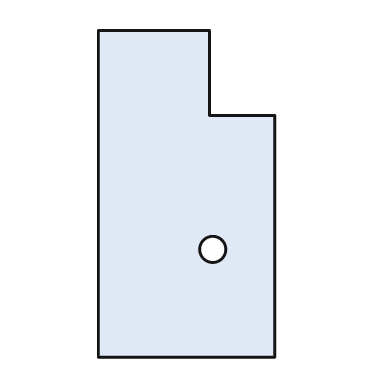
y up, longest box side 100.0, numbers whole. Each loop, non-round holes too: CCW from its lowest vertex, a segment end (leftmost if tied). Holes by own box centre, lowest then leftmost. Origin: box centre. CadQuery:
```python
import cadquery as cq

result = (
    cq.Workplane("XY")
    .moveTo(-27.0, -50.0)
    .lineTo(27.0, -50.0)
    .lineTo(27.0, 24.0)
    .lineTo(7.0, 24.0)
    .lineTo(7.0, 50.0)
    .lineTo(-27.0, 50.0)
    .close()
    .moveTo(8.0, -17.0)
    .circle(4.0)
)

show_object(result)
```